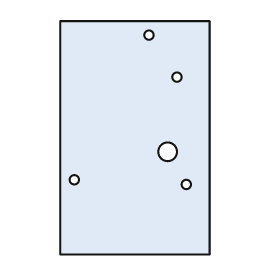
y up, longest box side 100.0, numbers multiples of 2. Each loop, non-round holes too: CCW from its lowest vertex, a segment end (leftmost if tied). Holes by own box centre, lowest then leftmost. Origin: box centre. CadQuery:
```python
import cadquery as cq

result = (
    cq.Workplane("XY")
    .moveTo(-32.0, -50.0)
    .lineTo(32.0, -50.0)
    .lineTo(32.0, 50.0)
    .lineTo(-32.0, 50.0)
    .close()
    .moveTo(22.0, -20.0)
    .circle(2.0)
    .moveTo(-26.0, -18.0)
    .circle(2.0)
    .moveTo(14.0, -6.0)
    .circle(4.0)
    .moveTo(18.0, 26.0)
    .circle(2.0)
    .moveTo(6.0, 44.0)
    .circle(2.0)
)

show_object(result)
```